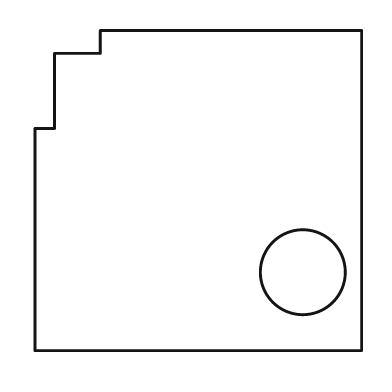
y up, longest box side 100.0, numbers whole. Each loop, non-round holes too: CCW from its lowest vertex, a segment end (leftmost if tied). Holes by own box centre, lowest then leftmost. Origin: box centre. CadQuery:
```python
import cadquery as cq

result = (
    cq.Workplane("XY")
    .moveTo(-50.0, -49.0)
    .lineTo(50.0, -49.0)
    .lineTo(50.0, 49.0)
    .lineTo(-30.0, 49.0)
    .lineTo(-30.0, 42.0)
    .lineTo(-44.0, 42.0)
    .lineTo(-44.0, 19.0)
    .lineTo(-50.0, 19.0)
    .close()
    .moveTo(32.0, -25.0)
    .circle(13.0)
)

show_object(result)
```